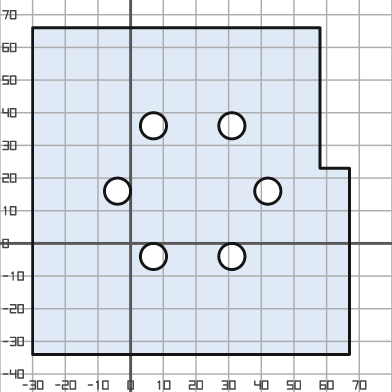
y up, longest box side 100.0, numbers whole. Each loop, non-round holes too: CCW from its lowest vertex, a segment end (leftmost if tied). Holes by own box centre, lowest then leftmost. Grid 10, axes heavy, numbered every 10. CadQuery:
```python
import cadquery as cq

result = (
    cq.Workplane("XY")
    .moveTo(-30.0, -34.0)
    .lineTo(67.0, -34.0)
    .lineTo(67.0, 23.0)
    .lineTo(58.0, 23.0)
    .lineTo(58.0, 66.0)
    .lineTo(-30.0, 66.0)
    .close()
    .moveTo(7.0, -4.0)
    .circle(4.0)
    .moveTo(31.0, -4.0)
    .circle(4.0)
    .moveTo(-4.0, 16.0)
    .circle(4.0)
    .moveTo(42.0, 16.0)
    .circle(4.0)
    .moveTo(7.0, 36.0)
    .circle(4.0)
    .moveTo(31.0, 36.0)
    .circle(4.0)
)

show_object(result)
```